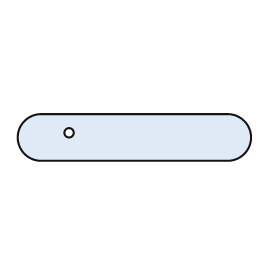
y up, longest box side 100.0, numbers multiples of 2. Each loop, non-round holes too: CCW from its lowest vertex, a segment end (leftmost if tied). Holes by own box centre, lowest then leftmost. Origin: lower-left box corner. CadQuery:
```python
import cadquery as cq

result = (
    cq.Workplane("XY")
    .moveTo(10.0, 0.0)
    .lineTo(90.0, 0.0)
    .threePointArc((100.0, 10.0), (90.0, 20.0))
    .lineTo(10.0, 20.0)
    .threePointArc((0.0, 10.0), (10.0, 0.0))
    .close()
    .moveTo(22.0, 12.0)
    .circle(2.0)
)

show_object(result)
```